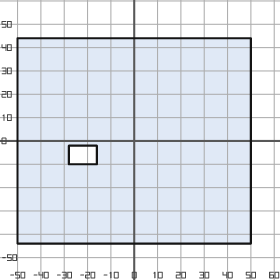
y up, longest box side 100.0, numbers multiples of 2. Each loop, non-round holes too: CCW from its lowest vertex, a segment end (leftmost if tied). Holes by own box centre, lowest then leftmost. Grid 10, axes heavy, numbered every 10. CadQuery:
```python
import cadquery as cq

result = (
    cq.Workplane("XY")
    .moveTo(-50.0, -44.0)
    .lineTo(50.0, -44.0)
    .lineTo(50.0, 44.0)
    .lineTo(-50.0, 44.0)
    .close()
    .moveTo(-28.0, -10.0)
    .lineTo(-16.0, -10.0)
    .lineTo(-16.0, -2.0)
    .lineTo(-28.0, -2.0)
    .close()
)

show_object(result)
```